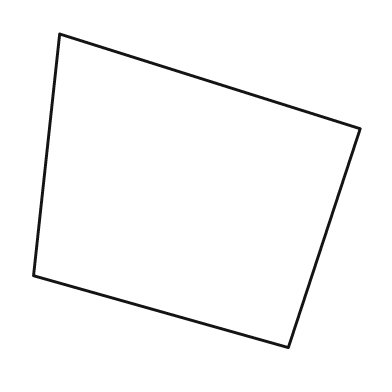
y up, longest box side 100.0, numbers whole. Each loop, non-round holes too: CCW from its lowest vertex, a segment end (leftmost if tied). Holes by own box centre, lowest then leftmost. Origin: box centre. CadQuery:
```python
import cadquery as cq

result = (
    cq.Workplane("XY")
    .moveTo(28.0, -48.0)
    .lineTo(50.0, 19.0)
    .lineTo(-42.0, 48.0)
    .lineTo(-50.0, -26.0)
    .close()
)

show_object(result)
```